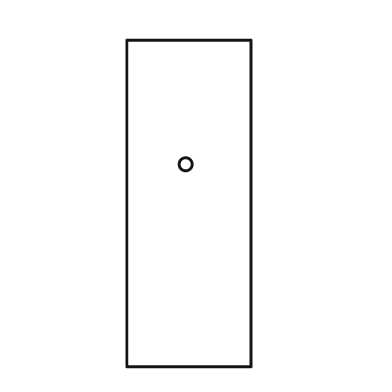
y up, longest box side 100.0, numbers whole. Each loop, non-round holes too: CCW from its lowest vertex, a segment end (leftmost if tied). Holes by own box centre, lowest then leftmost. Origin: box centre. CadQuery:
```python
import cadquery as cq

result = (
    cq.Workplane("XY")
    .moveTo(-19.0, -50.0)
    .lineTo(19.0, -50.0)
    .lineTo(19.0, 50.0)
    .lineTo(-19.0, 50.0)
    .close()
    .moveTo(-1.0, 12.0)
    .circle(2.0)
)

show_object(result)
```